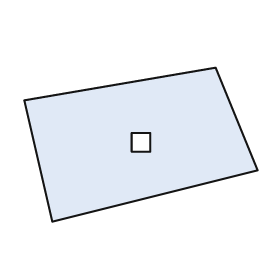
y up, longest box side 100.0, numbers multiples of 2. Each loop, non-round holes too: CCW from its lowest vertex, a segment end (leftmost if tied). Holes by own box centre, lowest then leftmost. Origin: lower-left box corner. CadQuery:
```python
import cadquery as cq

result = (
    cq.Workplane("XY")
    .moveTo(12.0, 0.0)
    .lineTo(100.0, 22.0)
    .lineTo(82.0, 66.0)
    .lineTo(0.0, 52.0)
    .close()
    .moveTo(46.0, 30.0)
    .lineTo(54.0, 30.0)
    .lineTo(54.0, 38.0)
    .lineTo(46.0, 38.0)
    .close()
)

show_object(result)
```